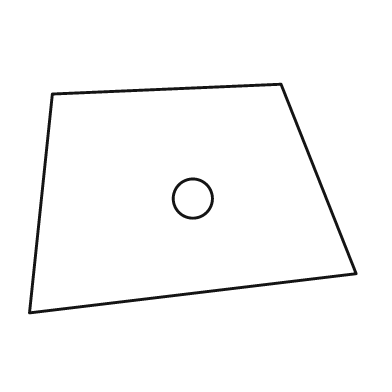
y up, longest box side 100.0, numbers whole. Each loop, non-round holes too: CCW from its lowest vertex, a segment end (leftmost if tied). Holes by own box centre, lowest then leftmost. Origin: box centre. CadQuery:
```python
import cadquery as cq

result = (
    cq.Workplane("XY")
    .moveTo(-50.0, -35.0)
    .lineTo(50.0, -23.0)
    .lineTo(27.0, 35.0)
    .lineTo(-43.0, 32.0)
    .close()
    .moveTo(0.0, 0.0)
    .circle(6.0)
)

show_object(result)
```